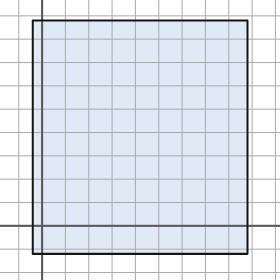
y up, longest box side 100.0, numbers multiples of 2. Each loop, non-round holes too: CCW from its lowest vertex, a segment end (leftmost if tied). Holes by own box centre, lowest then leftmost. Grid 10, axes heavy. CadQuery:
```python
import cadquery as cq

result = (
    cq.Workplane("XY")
    .moveTo(-4.0, -12.0)
    .lineTo(88.0, -12.0)
    .lineTo(88.0, 88.0)
    .lineTo(-4.0, 88.0)
    .close()
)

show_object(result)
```